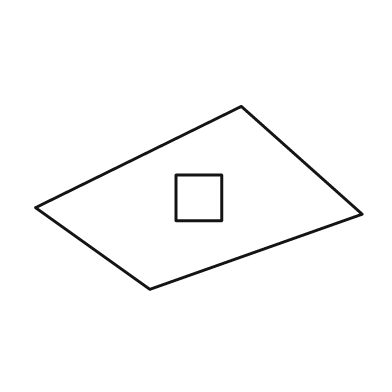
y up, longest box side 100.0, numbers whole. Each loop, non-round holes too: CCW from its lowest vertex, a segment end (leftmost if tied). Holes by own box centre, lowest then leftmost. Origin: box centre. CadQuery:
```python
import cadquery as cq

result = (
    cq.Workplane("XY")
    .moveTo(-15.0, -28.0)
    .lineTo(50.0, -5.0)
    .lineTo(13.0, 28.0)
    .lineTo(-50.0, -3.0)
    .close()
    .moveTo(-7.0, -7.0)
    .lineTo(7.0, -7.0)
    .lineTo(7.0, 7.0)
    .lineTo(-7.0, 7.0)
    .close()
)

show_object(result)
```